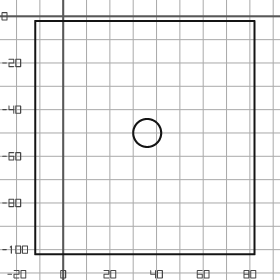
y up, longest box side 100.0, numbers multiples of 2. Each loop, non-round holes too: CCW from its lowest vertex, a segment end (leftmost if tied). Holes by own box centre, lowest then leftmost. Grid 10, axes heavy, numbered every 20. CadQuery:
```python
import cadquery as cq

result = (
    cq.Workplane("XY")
    .moveTo(-12.0, -102.0)
    .lineTo(82.0, -102.0)
    .lineTo(82.0, -2.0)
    .lineTo(-12.0, -2.0)
    .close()
    .moveTo(36.0, -50.0)
    .circle(6.0)
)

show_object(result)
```